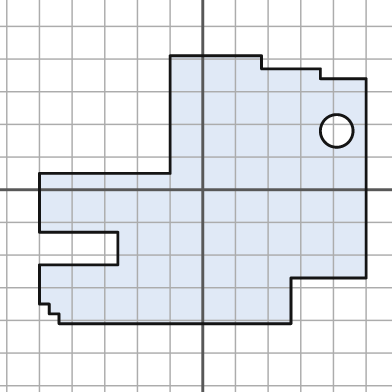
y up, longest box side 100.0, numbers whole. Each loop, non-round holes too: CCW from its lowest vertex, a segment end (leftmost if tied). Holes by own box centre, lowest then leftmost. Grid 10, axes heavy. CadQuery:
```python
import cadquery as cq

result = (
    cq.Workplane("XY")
    .moveTo(-44.0, -41.0)
    .lineTo(27.0, -41.0)
    .lineTo(27.0, -27.0)
    .lineTo(50.0, -27.0)
    .lineTo(50.0, 34.0)
    .lineTo(36.0, 34.0)
    .lineTo(36.0, 37.0)
    .lineTo(18.0, 37.0)
    .lineTo(18.0, 41.0)
    .lineTo(-10.0, 41.0)
    .lineTo(-10.0, 5.0)
    .lineTo(-50.0, 5.0)
    .lineTo(-50.0, -13.0)
    .lineTo(-26.0, -13.0)
    .lineTo(-26.0, -23.0)
    .lineTo(-50.0, -23.0)
    .lineTo(-50.0, -35.0)
    .lineTo(-47.0, -35.0)
    .lineTo(-47.0, -38.0)
    .lineTo(-44.0, -38.0)
    .close()
    .moveTo(41.0, 18.0)
    .circle(5.0)
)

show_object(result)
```